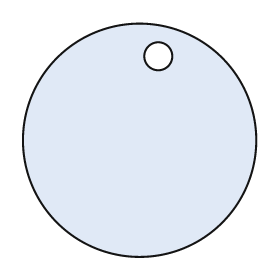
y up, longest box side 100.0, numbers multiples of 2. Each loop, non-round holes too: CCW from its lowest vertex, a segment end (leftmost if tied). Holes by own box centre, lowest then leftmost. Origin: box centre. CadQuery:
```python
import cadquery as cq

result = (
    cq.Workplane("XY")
    .moveTo(0.0, 0.0)
    .circle(50.0)
    .moveTo(8.0, 36.0)
    .circle(6.0)
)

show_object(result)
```